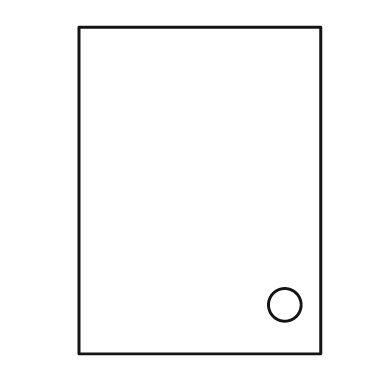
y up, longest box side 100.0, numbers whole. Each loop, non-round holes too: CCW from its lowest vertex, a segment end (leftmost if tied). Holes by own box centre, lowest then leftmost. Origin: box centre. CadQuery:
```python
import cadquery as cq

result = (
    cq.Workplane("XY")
    .moveTo(-37.0, -50.0)
    .lineTo(37.0, -50.0)
    .lineTo(37.0, 50.0)
    .lineTo(-37.0, 50.0)
    .close()
    .moveTo(26.0, -35.0)
    .circle(5.0)
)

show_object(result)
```